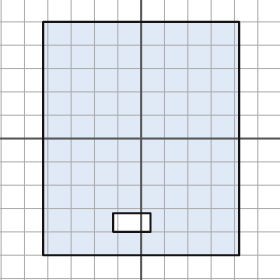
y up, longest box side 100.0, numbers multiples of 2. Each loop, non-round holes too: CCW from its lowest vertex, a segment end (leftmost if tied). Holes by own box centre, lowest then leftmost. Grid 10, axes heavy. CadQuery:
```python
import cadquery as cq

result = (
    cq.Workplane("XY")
    .moveTo(-42.0, -50.0)
    .lineTo(42.0, -50.0)
    .lineTo(42.0, 50.0)
    .lineTo(-42.0, 50.0)
    .close()
    .moveTo(-12.0, -40.0)
    .lineTo(4.0, -40.0)
    .lineTo(4.0, -32.0)
    .lineTo(-12.0, -32.0)
    .close()
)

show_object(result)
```